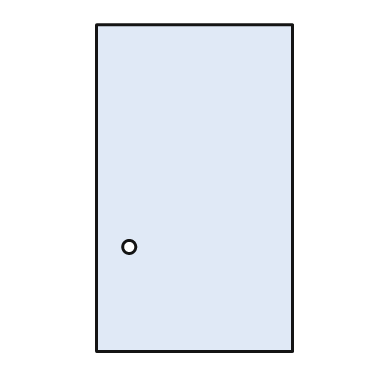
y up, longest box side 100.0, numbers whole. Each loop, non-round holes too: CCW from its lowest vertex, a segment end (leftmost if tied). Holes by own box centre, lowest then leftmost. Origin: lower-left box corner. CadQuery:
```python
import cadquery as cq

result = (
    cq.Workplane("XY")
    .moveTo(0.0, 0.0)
    .lineTo(60.0, 0.0)
    .lineTo(60.0, 100.0)
    .lineTo(0.0, 100.0)
    .close()
    .moveTo(10.0, 32.0)
    .circle(2.0)
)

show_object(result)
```